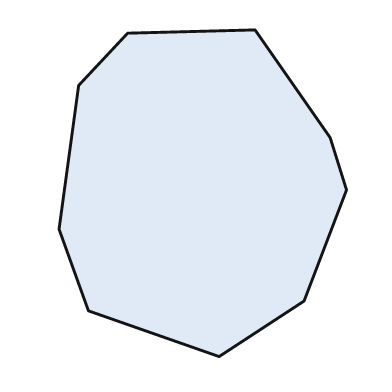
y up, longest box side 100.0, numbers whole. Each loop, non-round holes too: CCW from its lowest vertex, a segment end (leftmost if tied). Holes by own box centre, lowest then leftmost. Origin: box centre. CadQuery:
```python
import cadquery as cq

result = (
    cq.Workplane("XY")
    .moveTo(5.0, -50.0)
    .lineTo(31.0, -33.0)
    .lineTo(44.0, 1.0)
    .lineTo(39.0, 17.0)
    .lineTo(16.0, 50.0)
    .lineTo(-23.0, 49.0)
    .lineTo(-38.0, 33.0)
    .lineTo(-44.0, -11.0)
    .lineTo(-35.0, -36.0)
    .close()
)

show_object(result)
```